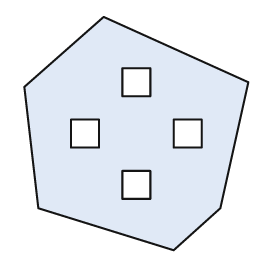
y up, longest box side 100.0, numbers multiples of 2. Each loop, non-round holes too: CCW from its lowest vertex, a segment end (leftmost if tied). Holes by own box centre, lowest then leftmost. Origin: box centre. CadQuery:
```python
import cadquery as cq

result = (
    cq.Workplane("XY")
    .moveTo(16.0, -50.0)
    .lineTo(36.0, -32.0)
    .lineTo(48.0, 22.0)
    .lineTo(-14.0, 50.0)
    .lineTo(-48.0, 20.0)
    .lineTo(-42.0, -32.0)
    .close()
    .moveTo(-6.0, -28.0)
    .lineTo(6.0, -28.0)
    .lineTo(6.0, -16.0)
    .lineTo(-6.0, -16.0)
    .close()
    .moveTo(-28.0, -6.0)
    .lineTo(-16.0, -6.0)
    .lineTo(-16.0, 6.0)
    .lineTo(-28.0, 6.0)
    .close()
    .moveTo(16.0, -6.0)
    .lineTo(28.0, -6.0)
    .lineTo(28.0, 6.0)
    .lineTo(16.0, 6.0)
    .close()
    .moveTo(-6.0, 16.0)
    .lineTo(6.0, 16.0)
    .lineTo(6.0, 28.0)
    .lineTo(-6.0, 28.0)
    .close()
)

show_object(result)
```